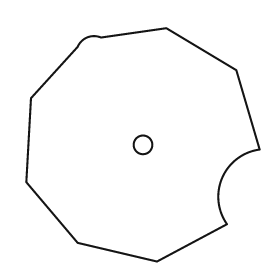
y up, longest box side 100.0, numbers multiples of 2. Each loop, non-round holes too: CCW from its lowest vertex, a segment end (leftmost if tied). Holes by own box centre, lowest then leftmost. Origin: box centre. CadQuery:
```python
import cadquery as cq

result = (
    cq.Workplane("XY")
    .moveTo(6.0, -50.0)
    .lineTo(36.0, -34.0)
    .threePointArc((34.0, -14.0), (50.0, -2.0))
    .lineTo(40.0, 32.0)
    .lineTo(10.0, 50.0)
    .lineTo(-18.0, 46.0)
    .threePointArc((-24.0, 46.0), (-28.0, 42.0))
    .lineTo(-48.0, 20.0)
    .lineTo(-50.0, -16.0)
    .lineTo(-28.0, -42.0)
    .close()
    .moveTo(0.0, 0.0)
    .circle(4.0)
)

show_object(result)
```